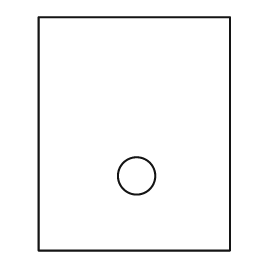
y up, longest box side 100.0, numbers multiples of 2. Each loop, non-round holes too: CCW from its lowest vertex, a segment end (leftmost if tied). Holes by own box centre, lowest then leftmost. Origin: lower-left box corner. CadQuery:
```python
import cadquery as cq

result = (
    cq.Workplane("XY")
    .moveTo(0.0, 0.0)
    .lineTo(82.0, 0.0)
    .lineTo(82.0, 100.0)
    .lineTo(0.0, 100.0)
    .close()
    .moveTo(42.0, 32.0)
    .circle(8.0)
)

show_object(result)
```